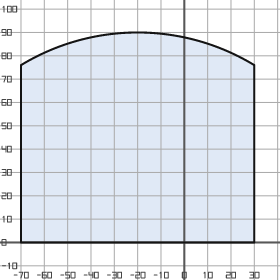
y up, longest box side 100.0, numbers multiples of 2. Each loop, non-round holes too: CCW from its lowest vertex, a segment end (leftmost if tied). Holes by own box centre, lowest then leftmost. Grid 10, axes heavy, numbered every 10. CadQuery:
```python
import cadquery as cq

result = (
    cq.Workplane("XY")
    .moveTo(-70.0, 0.0)
    .lineTo(30.0, 0.0)
    .lineTo(30.0, 76.0)
    .threePointArc((-20.0, 90.0), (-70.0, 76.0))
    .close()
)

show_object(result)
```